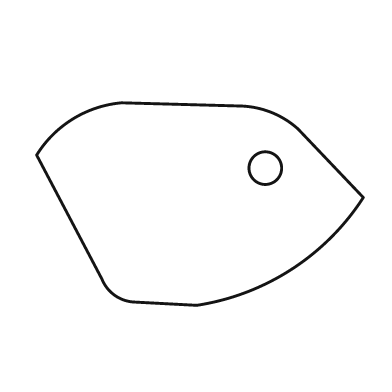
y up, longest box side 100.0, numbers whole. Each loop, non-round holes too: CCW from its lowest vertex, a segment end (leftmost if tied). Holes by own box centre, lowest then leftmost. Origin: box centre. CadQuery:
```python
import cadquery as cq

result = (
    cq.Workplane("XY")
    .moveTo(-1.0, -31.0)
    .threePointArc((28.0, -20.0), (50.0, 2.0))
    .lineTo(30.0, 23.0)
    .threePointArc((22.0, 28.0), (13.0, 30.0))
    .lineTo(-24.0, 31.0)
    .threePointArc((-39.0, 26.0), (-50.0, 15.0))
    .lineTo(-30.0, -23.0)
    .threePointArc((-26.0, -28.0), (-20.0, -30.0))
    .close()
    .moveTo(20.0, 11.0)
    .circle(5.0)
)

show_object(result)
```